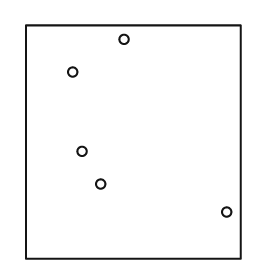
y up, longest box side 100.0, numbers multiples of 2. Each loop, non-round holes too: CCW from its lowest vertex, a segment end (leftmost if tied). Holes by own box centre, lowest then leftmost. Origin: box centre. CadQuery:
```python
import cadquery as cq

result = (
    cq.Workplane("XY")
    .moveTo(-46.0, -50.0)
    .lineTo(46.0, -50.0)
    .lineTo(46.0, 50.0)
    .lineTo(-46.0, 50.0)
    .close()
    .moveTo(40.0, -30.0)
    .circle(2.0)
    .moveTo(-14.0, -18.0)
    .circle(2.0)
    .moveTo(-22.0, -4.0)
    .circle(2.0)
    .moveTo(-26.0, 30.0)
    .circle(2.0)
    .moveTo(-4.0, 44.0)
    .circle(2.0)
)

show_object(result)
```